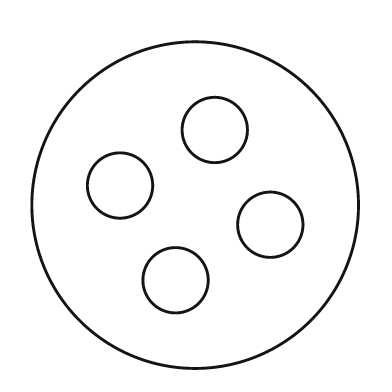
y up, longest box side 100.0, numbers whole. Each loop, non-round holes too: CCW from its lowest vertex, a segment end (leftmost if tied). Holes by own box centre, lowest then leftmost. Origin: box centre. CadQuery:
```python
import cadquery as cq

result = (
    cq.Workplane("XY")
    .moveTo(0.0, 0.0)
    .circle(50.0)
    .moveTo(-6.0, -23.0)
    .circle(10.0)
    .moveTo(23.0, -6.0)
    .circle(10.0)
    .moveTo(-23.0, 6.0)
    .circle(10.0)
    .moveTo(6.0, 23.0)
    .circle(10.0)
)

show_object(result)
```